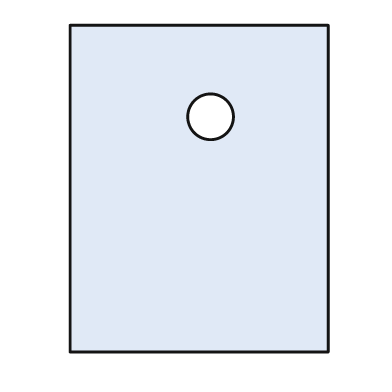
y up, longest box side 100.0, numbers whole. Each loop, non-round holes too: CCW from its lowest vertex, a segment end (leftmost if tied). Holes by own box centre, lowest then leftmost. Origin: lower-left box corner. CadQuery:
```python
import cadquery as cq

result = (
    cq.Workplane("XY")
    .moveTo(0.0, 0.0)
    .lineTo(79.0, 0.0)
    .lineTo(79.0, 100.0)
    .lineTo(0.0, 100.0)
    .close()
    .moveTo(43.0, 72.0)
    .circle(7.0)
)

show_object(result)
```